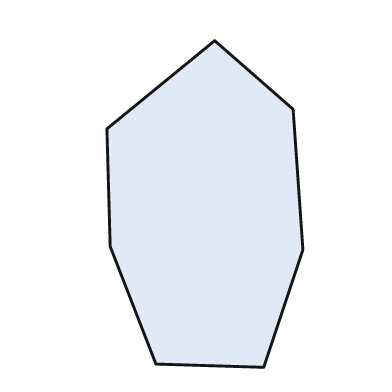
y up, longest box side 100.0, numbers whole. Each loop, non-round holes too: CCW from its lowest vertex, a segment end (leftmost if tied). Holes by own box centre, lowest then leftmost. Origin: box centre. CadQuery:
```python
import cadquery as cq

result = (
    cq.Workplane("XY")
    .moveTo(18.0, -50.0)
    .lineTo(30.0, -14.0)
    .lineTo(27.0, 29.0)
    .lineTo(3.0, 50.0)
    .lineTo(-30.0, 23.0)
    .lineTo(-29.0, -13.0)
    .lineTo(-15.0, -49.0)
    .close()
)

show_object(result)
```